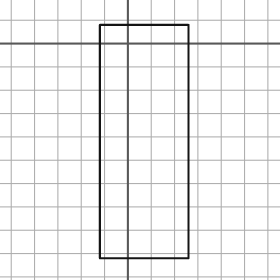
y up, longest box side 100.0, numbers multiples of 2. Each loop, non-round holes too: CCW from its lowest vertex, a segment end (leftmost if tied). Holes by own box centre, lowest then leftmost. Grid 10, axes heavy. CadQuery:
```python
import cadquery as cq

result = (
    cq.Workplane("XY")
    .moveTo(-12.0, -92.0)
    .lineTo(26.0, -92.0)
    .lineTo(26.0, 8.0)
    .lineTo(-12.0, 8.0)
    .close()
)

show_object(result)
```